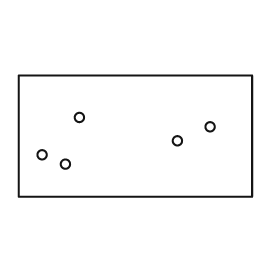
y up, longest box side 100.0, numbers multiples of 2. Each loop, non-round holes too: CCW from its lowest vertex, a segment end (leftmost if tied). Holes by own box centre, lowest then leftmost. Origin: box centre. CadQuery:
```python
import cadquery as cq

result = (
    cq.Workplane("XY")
    .moveTo(-50.0, -26.0)
    .lineTo(50.0, -26.0)
    .lineTo(50.0, 26.0)
    .lineTo(-50.0, 26.0)
    .close()
    .moveTo(-30.0, -12.0)
    .circle(2.0)
    .moveTo(-40.0, -8.0)
    .circle(2.0)
    .moveTo(18.0, -2.0)
    .circle(2.0)
    .moveTo(32.0, 4.0)
    .circle(2.0)
    .moveTo(-24.0, 8.0)
    .circle(2.0)
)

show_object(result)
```